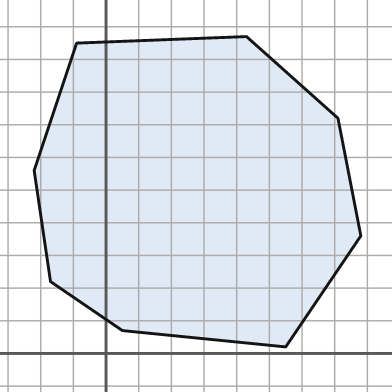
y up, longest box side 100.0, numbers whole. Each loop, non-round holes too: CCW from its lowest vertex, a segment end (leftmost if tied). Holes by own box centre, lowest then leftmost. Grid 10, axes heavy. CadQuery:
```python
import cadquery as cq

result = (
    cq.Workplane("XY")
    .moveTo(55.0, 2.0)
    .lineTo(78.0, 36.0)
    .lineTo(71.0, 72.0)
    .lineTo(43.0, 97.0)
    .lineTo(-9.0, 95.0)
    .lineTo(-22.0, 56.0)
    .lineTo(-17.0, 22.0)
    .lineTo(5.0, 7.0)
    .close()
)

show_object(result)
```